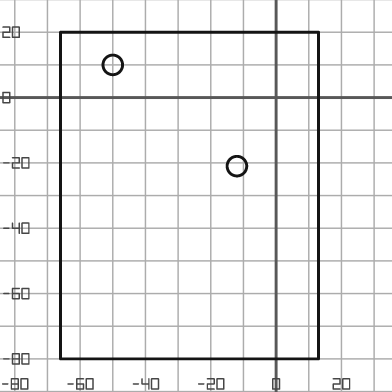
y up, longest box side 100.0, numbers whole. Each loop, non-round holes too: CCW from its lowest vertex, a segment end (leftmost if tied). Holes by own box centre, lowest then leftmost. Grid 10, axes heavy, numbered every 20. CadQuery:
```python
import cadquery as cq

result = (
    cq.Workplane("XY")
    .moveTo(-66.0, -80.0)
    .lineTo(13.0, -80.0)
    .lineTo(13.0, 20.0)
    .lineTo(-66.0, 20.0)
    .close()
    .moveTo(-12.0, -21.0)
    .circle(3.0)
    .moveTo(-50.0, 10.0)
    .circle(3.0)
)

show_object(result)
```